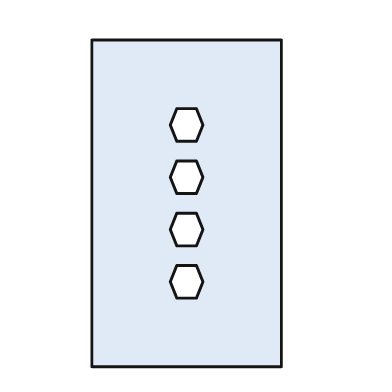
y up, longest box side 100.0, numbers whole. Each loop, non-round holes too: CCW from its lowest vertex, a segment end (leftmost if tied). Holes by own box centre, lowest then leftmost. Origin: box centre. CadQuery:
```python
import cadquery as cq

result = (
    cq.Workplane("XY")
    .moveTo(-29.0, -50.0)
    .lineTo(29.0, -50.0)
    .lineTo(29.0, 50.0)
    .lineTo(-29.0, 50.0)
    .close()
    .moveTo(-3.0, -29.0)
    .lineTo(3.0, -29.0)
    .lineTo(5.0, -24.0)
    .lineTo(3.0, -19.0)
    .lineTo(-3.0, -19.0)
    .lineTo(-5.0, -24.0)
    .close()
    .moveTo(-3.0, -13.0)
    .lineTo(3.0, -13.0)
    .lineTo(5.0, -8.0)
    .lineTo(3.0, -3.0)
    .lineTo(-3.0, -3.0)
    .lineTo(-5.0, -8.0)
    .close()
    .moveTo(-3.0, 3.0)
    .lineTo(3.0, 3.0)
    .lineTo(5.0, 8.0)
    .lineTo(3.0, 13.0)
    .lineTo(-3.0, 13.0)
    .lineTo(-5.0, 8.0)
    .close()
    .moveTo(-3.0, 19.0)
    .lineTo(3.0, 19.0)
    .lineTo(5.0, 24.0)
    .lineTo(3.0, 29.0)
    .lineTo(-3.0, 29.0)
    .lineTo(-5.0, 24.0)
    .close()
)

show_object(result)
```